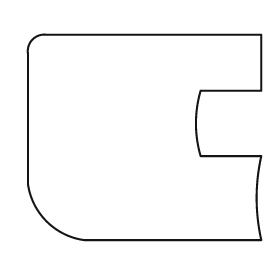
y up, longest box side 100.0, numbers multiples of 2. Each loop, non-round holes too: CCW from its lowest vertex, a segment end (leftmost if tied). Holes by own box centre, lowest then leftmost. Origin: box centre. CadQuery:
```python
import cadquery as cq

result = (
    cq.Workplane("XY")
    .moveTo(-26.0, -44.0)
    .lineTo(50.0, -44.0)
    .threePointArc((48.0, -26.0), (50.0, -8.0))
    .lineTo(24.0, -8.0)
    .threePointArc((22.0, 6.0), (24.0, 20.0))
    .lineTo(50.0, 20.0)
    .lineTo(50.0, 44.0)
    .lineTo(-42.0, 44.0)
    .threePointArc((-48.0, 42.0), (-50.0, 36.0))
    .lineTo(-50.0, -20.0)
    .threePointArc((-42.0, -36.0), (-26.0, -44.0))
    .close()
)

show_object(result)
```